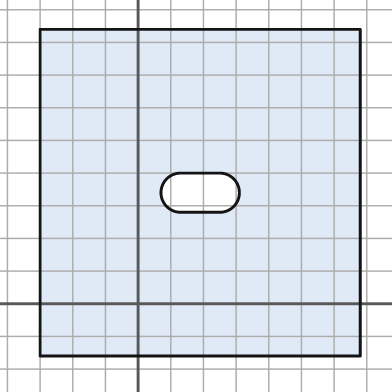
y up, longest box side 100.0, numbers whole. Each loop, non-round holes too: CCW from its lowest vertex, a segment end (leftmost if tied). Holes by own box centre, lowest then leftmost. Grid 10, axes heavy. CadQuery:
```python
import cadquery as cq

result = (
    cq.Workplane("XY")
    .moveTo(-30.0, -16.0)
    .lineTo(68.0, -16.0)
    .lineTo(68.0, 84.0)
    .lineTo(-30.0, 84.0)
    .close()
    .moveTo(13.0, 28.0)
    .lineTo(25.0, 28.0)
    .threePointArc((31.0, 34.0), (25.0, 40.0))
    .lineTo(13.0, 40.0)
    .threePointArc((7.0, 34.0), (13.0, 28.0))
    .close()
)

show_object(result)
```